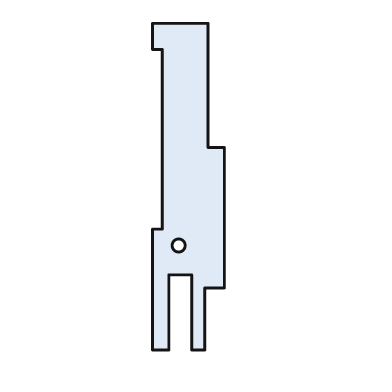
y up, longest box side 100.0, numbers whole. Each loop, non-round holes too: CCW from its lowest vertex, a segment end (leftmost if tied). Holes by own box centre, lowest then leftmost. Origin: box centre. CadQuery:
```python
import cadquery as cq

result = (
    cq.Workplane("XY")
    .moveTo(-11.0, -50.0)
    .lineTo(-6.0, -50.0)
    .lineTo(-6.0, -27.0)
    .lineTo(1.0, -27.0)
    .lineTo(1.0, -50.0)
    .lineTo(5.0, -50.0)
    .lineTo(5.0, -31.0)
    .lineTo(11.0, -31.0)
    .lineTo(11.0, 12.0)
    .lineTo(6.0, 12.0)
    .lineTo(6.0, 50.0)
    .lineTo(-11.0, 50.0)
    .lineTo(-11.0, 42.0)
    .lineTo(-8.0, 42.0)
    .lineTo(-8.0, -13.0)
    .lineTo(-11.0, -13.0)
    .close()
    .moveTo(-3.0, -18.0)
    .circle(2.0)
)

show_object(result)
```